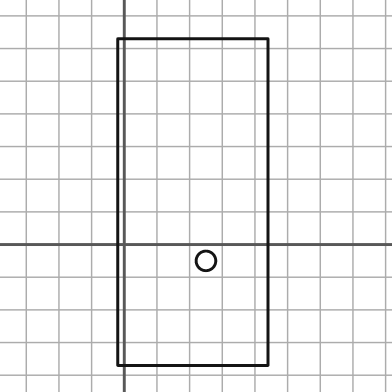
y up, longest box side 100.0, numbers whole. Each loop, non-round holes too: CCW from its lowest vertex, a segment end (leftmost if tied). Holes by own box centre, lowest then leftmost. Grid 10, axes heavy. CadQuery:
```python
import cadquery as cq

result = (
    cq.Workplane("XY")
    .moveTo(-2.0, -37.0)
    .lineTo(44.0, -37.0)
    .lineTo(44.0, 63.0)
    .lineTo(-2.0, 63.0)
    .close()
    .moveTo(25.0, -5.0)
    .circle(3.0)
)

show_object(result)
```